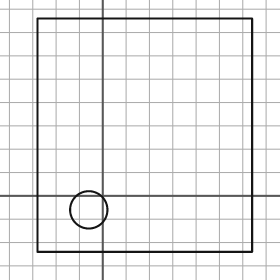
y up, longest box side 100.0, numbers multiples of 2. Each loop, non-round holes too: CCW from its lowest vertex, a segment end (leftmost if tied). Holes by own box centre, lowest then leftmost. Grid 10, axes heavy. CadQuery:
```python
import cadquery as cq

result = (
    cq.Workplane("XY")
    .moveTo(-28.0, -24.0)
    .lineTo(64.0, -24.0)
    .lineTo(64.0, 76.0)
    .lineTo(-28.0, 76.0)
    .close()
    .moveTo(-6.0, -6.0)
    .circle(8.0)
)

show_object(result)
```